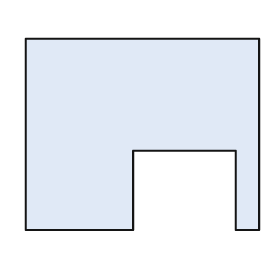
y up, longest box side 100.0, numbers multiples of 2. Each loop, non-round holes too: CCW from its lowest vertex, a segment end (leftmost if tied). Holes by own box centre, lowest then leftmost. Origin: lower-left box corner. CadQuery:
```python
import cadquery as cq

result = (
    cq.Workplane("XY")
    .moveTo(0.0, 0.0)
    .lineTo(46.0, 0.0)
    .lineTo(46.0, 34.0)
    .lineTo(90.0, 34.0)
    .lineTo(90.0, 0.0)
    .lineTo(100.0, 0.0)
    .lineTo(100.0, 82.0)
    .lineTo(0.0, 82.0)
    .close()
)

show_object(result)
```